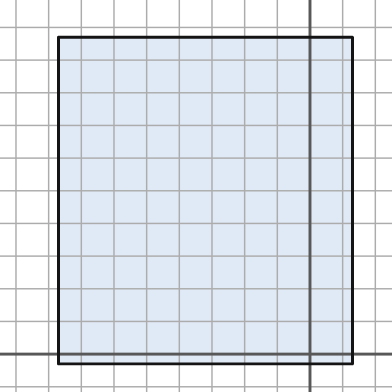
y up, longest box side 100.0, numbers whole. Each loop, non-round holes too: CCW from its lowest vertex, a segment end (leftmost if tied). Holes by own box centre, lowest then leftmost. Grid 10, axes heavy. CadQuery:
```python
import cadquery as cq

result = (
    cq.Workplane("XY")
    .moveTo(-77.0, -3.0)
    .lineTo(13.0, -3.0)
    .lineTo(13.0, 97.0)
    .lineTo(-77.0, 97.0)
    .close()
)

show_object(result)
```